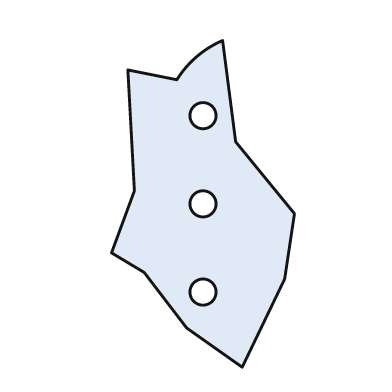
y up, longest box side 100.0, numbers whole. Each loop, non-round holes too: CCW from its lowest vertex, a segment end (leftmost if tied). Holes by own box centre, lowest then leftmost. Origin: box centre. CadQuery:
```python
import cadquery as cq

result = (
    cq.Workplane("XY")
    .moveTo(12.0, -50.0)
    .lineTo(25.0, -23.0)
    .lineTo(28.0, -3.0)
    .lineTo(10.0, 19.0)
    .lineTo(6.0, 50.0)
    .threePointArc((-2.0, 45.0), (-8.0, 38.0))
    .lineTo(-23.0, 41.0)
    .lineTo(-21.0, 4.0)
    .lineTo(-28.0, -15.0)
    .lineTo(-18.0, -21.0)
    .lineTo(-5.0, -38.0)
    .close()
    .moveTo(0.0, -27.0)
    .circle(4.0)
    .moveTo(0.0, 0.0)
    .circle(4.0)
    .moveTo(0.0, 27.0)
    .circle(4.0)
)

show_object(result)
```